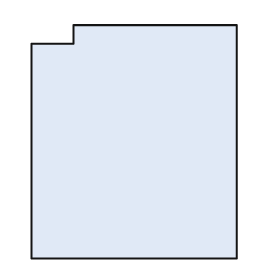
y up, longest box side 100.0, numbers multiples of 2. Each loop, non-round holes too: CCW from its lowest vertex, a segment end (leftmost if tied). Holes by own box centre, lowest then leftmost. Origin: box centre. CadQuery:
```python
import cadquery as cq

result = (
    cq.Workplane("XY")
    .moveTo(-44.0, -50.0)
    .lineTo(44.0, -50.0)
    .lineTo(44.0, 50.0)
    .lineTo(-26.0, 50.0)
    .lineTo(-26.0, 42.0)
    .lineTo(-44.0, 42.0)
    .close()
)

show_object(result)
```